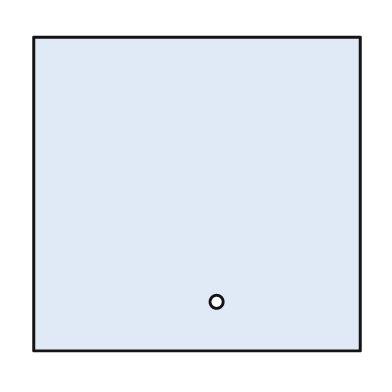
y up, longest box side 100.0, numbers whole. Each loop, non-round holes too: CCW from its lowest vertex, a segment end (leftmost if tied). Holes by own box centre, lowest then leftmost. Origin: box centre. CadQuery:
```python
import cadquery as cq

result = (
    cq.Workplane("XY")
    .moveTo(-50.0, -48.0)
    .lineTo(50.0, -48.0)
    .lineTo(50.0, 48.0)
    .lineTo(-50.0, 48.0)
    .close()
    .moveTo(6.0, -33.0)
    .circle(2.0)
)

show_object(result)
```